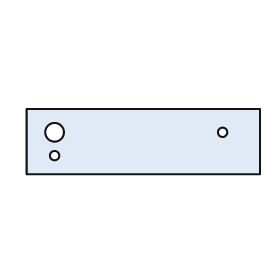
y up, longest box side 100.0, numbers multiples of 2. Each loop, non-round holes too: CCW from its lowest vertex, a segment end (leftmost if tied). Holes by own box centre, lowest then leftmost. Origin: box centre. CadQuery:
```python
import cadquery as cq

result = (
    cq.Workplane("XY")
    .moveTo(-50.0, -14.0)
    .lineTo(50.0, -14.0)
    .lineTo(50.0, 14.0)
    .lineTo(-50.0, 14.0)
    .close()
    .moveTo(-38.0, -6.0)
    .circle(2.0)
    .moveTo(-38.0, 4.0)
    .circle(4.0)
    .moveTo(34.0, 4.0)
    .circle(2.0)
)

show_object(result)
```